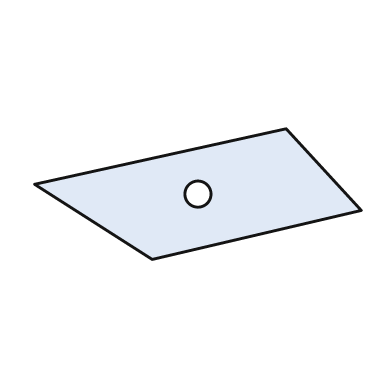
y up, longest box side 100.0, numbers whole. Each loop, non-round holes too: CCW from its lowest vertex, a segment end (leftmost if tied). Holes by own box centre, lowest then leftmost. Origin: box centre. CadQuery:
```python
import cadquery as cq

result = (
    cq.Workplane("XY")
    .moveTo(-14.0, -20.0)
    .lineTo(50.0, -5.0)
    .lineTo(27.0, 20.0)
    .lineTo(-50.0, 3.0)
    .close()
    .moveTo(0.0, 0.0)
    .circle(4.0)
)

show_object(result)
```